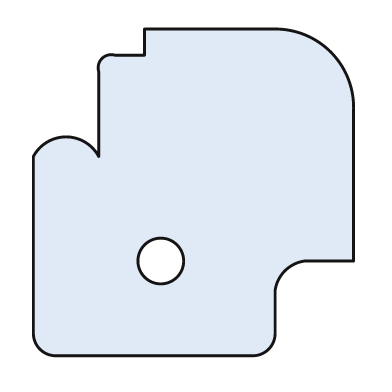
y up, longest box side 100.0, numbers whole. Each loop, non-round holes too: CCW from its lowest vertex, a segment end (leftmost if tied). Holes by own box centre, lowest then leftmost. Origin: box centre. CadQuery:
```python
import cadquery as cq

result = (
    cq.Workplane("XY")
    .moveTo(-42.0, -50.0)
    .lineTo(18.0, -50.0)
    .threePointArc((23.0, -48.0), (25.0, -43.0))
    .lineTo(25.0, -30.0)
    .threePointArc((28.0, -24.0), (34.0, -21.0))
    .lineTo(49.0, -21.0)
    .lineTo(49.0, 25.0)
    .threePointArc((42.0, 43.0), (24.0, 50.0))
    .lineTo(-15.0, 50.0)
    .lineTo(-15.0, 42.0)
    .lineTo(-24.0, 42.0)
    .threePointArc((-28.0, 41.0), (-29.0, 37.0))
    .lineTo(-29.0, 11.0)
    .threePointArc((-39.0, 17.0), (-49.0, 11.0))
    .lineTo(-49.0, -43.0)
    .threePointArc((-47.0, -48.0), (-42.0, -50.0))
    .close()
    .moveTo(-10.0, -21.0)
    .circle(7.0)
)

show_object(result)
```